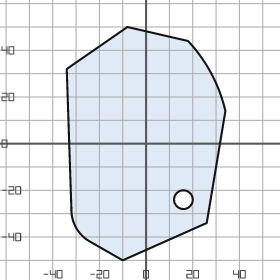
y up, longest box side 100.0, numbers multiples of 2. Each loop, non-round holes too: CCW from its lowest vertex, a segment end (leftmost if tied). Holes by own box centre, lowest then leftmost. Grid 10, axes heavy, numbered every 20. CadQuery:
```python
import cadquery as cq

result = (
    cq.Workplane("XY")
    .moveTo(-10.0, -50.0)
    .lineTo(26.0, -34.0)
    .lineTo(34.0, 14.0)
    .threePointArc((28.0, 30.0), (18.0, 44.0))
    .lineTo(-8.0, 50.0)
    .lineTo(-34.0, 32.0)
    .lineTo(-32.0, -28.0)
    .threePointArc((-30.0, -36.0), (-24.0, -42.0))
    .close()
    .moveTo(16.0, -24.0)
    .circle(4.0)
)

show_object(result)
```